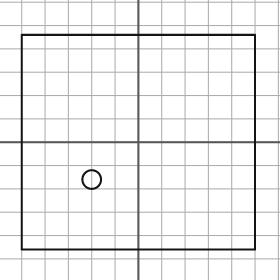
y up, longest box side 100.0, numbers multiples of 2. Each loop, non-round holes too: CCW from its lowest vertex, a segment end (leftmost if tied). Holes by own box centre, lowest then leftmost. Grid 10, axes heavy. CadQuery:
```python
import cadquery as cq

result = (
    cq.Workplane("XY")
    .moveTo(-50.0, -46.0)
    .lineTo(50.0, -46.0)
    .lineTo(50.0, 46.0)
    .lineTo(-50.0, 46.0)
    .close()
    .moveTo(-20.0, -16.0)
    .circle(4.0)
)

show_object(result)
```